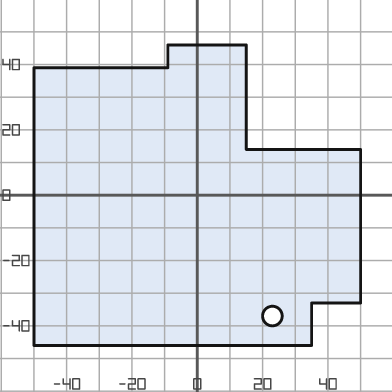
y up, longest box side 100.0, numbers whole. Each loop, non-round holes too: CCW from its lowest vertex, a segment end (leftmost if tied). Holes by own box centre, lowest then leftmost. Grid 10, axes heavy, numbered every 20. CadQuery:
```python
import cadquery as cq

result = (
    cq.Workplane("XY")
    .moveTo(-50.0, -46.0)
    .lineTo(35.0, -46.0)
    .lineTo(35.0, -33.0)
    .lineTo(50.0, -33.0)
    .lineTo(50.0, 14.0)
    .lineTo(15.0, 14.0)
    .lineTo(15.0, 46.0)
    .lineTo(-9.0, 46.0)
    .lineTo(-9.0, 39.0)
    .lineTo(-50.0, 39.0)
    .close()
    .moveTo(23.0, -37.0)
    .circle(3.0)
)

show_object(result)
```